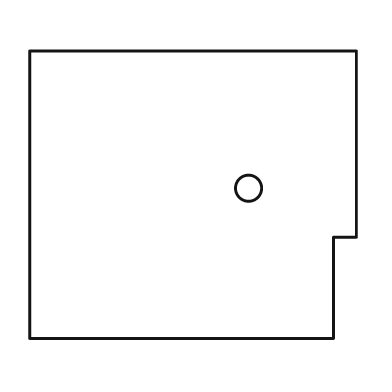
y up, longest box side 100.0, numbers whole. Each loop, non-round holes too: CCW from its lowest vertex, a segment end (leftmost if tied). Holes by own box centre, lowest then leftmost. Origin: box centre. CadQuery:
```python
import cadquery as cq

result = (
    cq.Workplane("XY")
    .moveTo(-50.0, -44.0)
    .lineTo(43.0, -44.0)
    .lineTo(43.0, -13.0)
    .lineTo(50.0, -13.0)
    .lineTo(50.0, 44.0)
    .lineTo(-50.0, 44.0)
    .close()
    .moveTo(17.0, 2.0)
    .circle(4.0)
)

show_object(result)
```